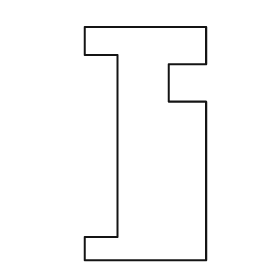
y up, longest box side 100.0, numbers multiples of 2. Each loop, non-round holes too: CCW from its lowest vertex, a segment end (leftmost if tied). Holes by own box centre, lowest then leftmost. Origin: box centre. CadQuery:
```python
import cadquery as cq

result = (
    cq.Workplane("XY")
    .moveTo(-26.0, -50.0)
    .lineTo(26.0, -50.0)
    .lineTo(26.0, 18.0)
    .lineTo(10.0, 18.0)
    .lineTo(10.0, 34.0)
    .lineTo(26.0, 34.0)
    .lineTo(26.0, 50.0)
    .lineTo(-26.0, 50.0)
    .lineTo(-26.0, 38.0)
    .lineTo(-12.0, 38.0)
    .lineTo(-12.0, -40.0)
    .lineTo(-26.0, -40.0)
    .close()
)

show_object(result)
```